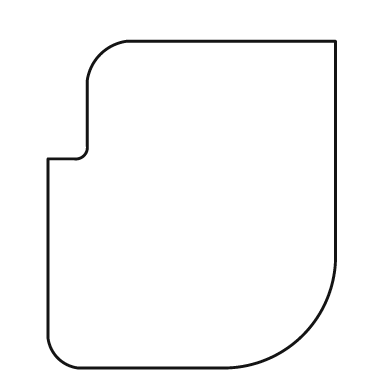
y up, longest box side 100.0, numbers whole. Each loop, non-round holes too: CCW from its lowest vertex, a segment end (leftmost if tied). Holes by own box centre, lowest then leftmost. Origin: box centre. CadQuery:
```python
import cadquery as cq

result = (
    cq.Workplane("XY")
    .moveTo(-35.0, -50.0)
    .lineTo(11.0, -50.0)
    .threePointArc((34.0, -40.0), (44.0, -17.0))
    .lineTo(44.0, 50.0)
    .lineTo(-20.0, 50.0)
    .threePointArc((-28.0, 46.0), (-32.0, 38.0))
    .lineTo(-32.0, 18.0)
    .threePointArc((-33.0, 15.0), (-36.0, 14.0))
    .lineTo(-44.0, 14.0)
    .lineTo(-44.0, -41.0)
    .threePointArc((-41.0, -47.0), (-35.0, -50.0))
    .close()
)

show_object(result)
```